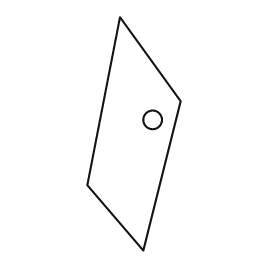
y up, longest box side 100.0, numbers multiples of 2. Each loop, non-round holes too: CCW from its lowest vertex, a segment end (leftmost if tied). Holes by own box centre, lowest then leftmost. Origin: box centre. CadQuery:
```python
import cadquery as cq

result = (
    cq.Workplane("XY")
    .moveTo(4.0, -50.0)
    .lineTo(20.0, 14.0)
    .lineTo(-6.0, 50.0)
    .lineTo(-20.0, -22.0)
    .close()
    .moveTo(8.0, 6.0)
    .circle(4.0)
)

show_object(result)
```